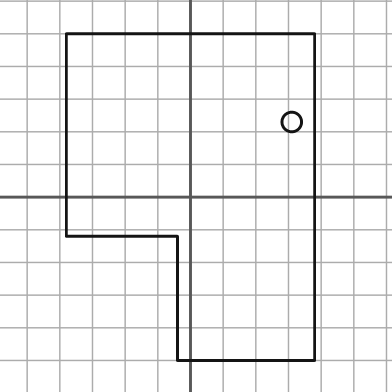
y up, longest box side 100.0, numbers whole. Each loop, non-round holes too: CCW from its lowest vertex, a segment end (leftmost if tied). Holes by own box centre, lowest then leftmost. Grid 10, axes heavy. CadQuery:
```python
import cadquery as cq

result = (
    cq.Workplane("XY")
    .moveTo(-4.0, -50.0)
    .lineTo(38.0, -50.0)
    .lineTo(38.0, 50.0)
    .lineTo(-38.0, 50.0)
    .lineTo(-38.0, -12.0)
    .lineTo(-4.0, -12.0)
    .close()
    .moveTo(31.0, 23.0)
    .circle(3.0)
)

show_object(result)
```